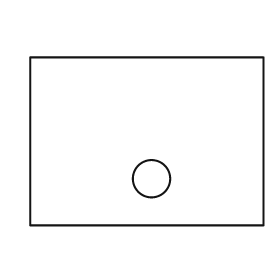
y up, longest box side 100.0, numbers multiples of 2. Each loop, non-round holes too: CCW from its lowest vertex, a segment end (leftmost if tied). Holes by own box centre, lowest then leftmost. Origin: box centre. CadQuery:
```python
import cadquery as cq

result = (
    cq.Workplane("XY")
    .moveTo(-50.0, -36.0)
    .lineTo(50.0, -36.0)
    .lineTo(50.0, 36.0)
    .lineTo(-50.0, 36.0)
    .close()
    .moveTo(2.0, -16.0)
    .circle(8.0)
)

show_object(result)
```